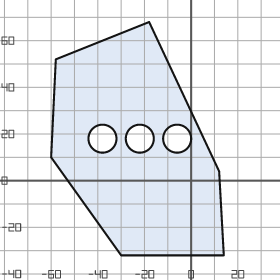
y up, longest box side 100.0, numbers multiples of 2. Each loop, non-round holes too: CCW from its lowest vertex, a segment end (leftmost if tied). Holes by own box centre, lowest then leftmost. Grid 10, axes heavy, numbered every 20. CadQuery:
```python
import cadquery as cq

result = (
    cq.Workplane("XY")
    .moveTo(-30.0, -32.0)
    .lineTo(14.0, -32.0)
    .lineTo(12.0, 4.0)
    .lineTo(-18.0, 68.0)
    .lineTo(-58.0, 52.0)
    .lineTo(-60.0, 10.0)
    .close()
    .moveTo(-38.0, 18.0)
    .circle(6.0)
    .moveTo(-22.0, 18.0)
    .circle(6.0)
    .moveTo(-6.0, 18.0)
    .circle(6.0)
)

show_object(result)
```